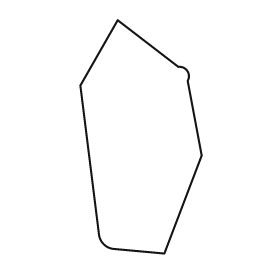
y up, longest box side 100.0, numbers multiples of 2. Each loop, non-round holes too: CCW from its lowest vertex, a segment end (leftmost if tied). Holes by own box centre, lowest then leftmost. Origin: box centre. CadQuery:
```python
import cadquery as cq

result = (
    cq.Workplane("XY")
    .moveTo(10.0, -50.0)
    .lineTo(26.0, -8.0)
    .lineTo(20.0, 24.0)
    .threePointArc((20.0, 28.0), (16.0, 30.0))
    .lineTo(-10.0, 50.0)
    .lineTo(-26.0, 22.0)
    .lineTo(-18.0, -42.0)
    .threePointArc((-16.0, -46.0), (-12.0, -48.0))
    .close()
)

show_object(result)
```